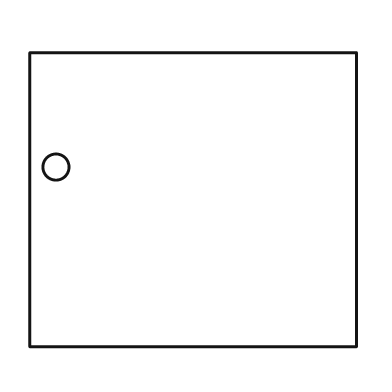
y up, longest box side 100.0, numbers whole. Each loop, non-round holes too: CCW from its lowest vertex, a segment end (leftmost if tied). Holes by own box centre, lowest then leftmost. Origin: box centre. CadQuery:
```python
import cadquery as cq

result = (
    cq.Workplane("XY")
    .moveTo(-50.0, -45.0)
    .lineTo(50.0, -45.0)
    .lineTo(50.0, 45.0)
    .lineTo(-50.0, 45.0)
    .close()
    .moveTo(-42.0, 10.0)
    .circle(4.0)
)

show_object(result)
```